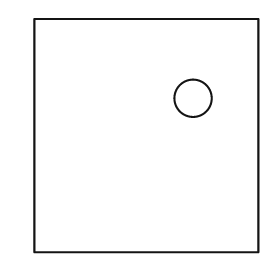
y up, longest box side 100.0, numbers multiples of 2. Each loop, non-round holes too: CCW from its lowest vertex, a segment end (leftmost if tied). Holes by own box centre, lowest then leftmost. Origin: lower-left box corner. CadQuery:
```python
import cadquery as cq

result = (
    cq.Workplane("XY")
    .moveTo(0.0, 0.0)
    .lineTo(96.0, 0.0)
    .lineTo(96.0, 100.0)
    .lineTo(0.0, 100.0)
    .close()
    .moveTo(68.0, 66.0)
    .circle(8.0)
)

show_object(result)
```